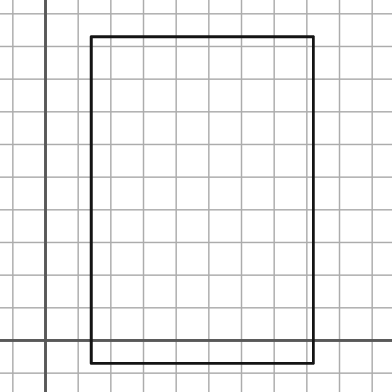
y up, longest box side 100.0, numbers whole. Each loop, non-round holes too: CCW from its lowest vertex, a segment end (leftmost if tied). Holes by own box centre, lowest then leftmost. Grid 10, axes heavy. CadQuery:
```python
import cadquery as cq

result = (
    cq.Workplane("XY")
    .moveTo(14.0, -7.0)
    .lineTo(82.0, -7.0)
    .lineTo(82.0, 93.0)
    .lineTo(14.0, 93.0)
    .close()
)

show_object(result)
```